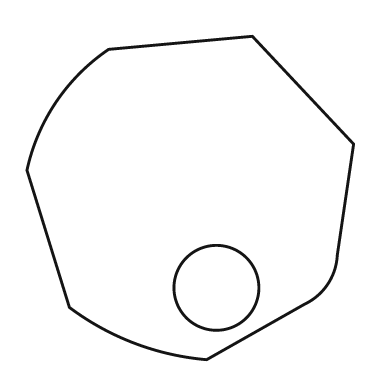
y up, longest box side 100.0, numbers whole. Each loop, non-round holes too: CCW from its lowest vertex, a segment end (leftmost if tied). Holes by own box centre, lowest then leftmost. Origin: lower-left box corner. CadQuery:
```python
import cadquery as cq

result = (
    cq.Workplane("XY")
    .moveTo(55.0, 0.0)
    .lineTo(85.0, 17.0)
    .threePointArc((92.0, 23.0), (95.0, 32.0))
    .lineTo(100.0, 66.0)
    .lineTo(69.0, 99.0)
    .lineTo(25.0, 95.0)
    .threePointArc((9.0, 79.0), (0.0, 58.0))
    .lineTo(13.0, 16.0)
    .threePointArc((33.0, 5.0), (55.0, 0.0))
    .close()
    .moveTo(58.0, 22.0)
    .circle(13.0)
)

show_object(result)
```